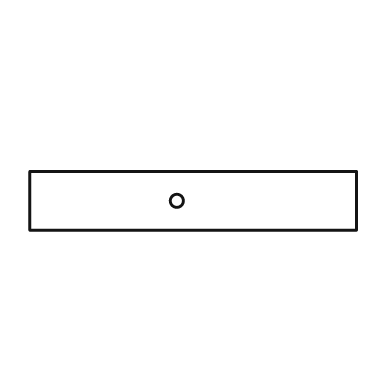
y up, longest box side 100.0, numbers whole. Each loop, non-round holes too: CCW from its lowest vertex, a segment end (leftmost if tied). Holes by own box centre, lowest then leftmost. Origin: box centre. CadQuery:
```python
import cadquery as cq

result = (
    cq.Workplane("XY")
    .moveTo(-50.0, -9.0)
    .lineTo(50.0, -9.0)
    .lineTo(50.0, 9.0)
    .lineTo(-50.0, 9.0)
    .close()
    .moveTo(-5.0, 0.0)
    .circle(2.0)
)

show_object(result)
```